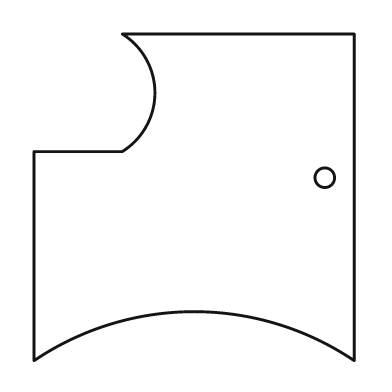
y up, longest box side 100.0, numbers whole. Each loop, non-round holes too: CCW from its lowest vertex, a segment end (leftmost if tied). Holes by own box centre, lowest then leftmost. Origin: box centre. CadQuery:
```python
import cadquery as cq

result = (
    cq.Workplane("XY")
    .moveTo(-49.0, -50.0)
    .threePointArc((0.0, -35.0), (49.0, -50.0))
    .lineTo(49.0, 50.0)
    .lineTo(-22.0, 50.0)
    .threePointArc((-12.0, 32.0), (-22.0, 14.0))
    .lineTo(-49.0, 14.0)
    .close()
    .moveTo(40.0, 6.0)
    .circle(3.0)
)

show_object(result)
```